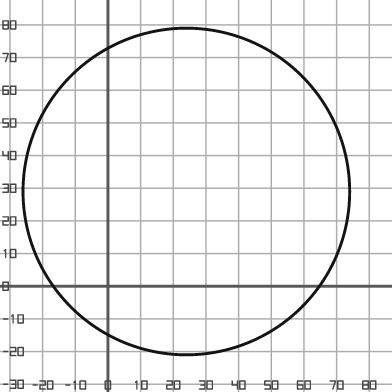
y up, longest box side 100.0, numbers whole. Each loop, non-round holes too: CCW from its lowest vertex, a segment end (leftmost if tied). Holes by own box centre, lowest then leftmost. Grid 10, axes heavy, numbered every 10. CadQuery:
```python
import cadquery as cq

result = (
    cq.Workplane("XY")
    .moveTo(24.0, 29.0)
    .circle(50.0)
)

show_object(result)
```